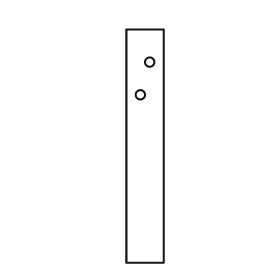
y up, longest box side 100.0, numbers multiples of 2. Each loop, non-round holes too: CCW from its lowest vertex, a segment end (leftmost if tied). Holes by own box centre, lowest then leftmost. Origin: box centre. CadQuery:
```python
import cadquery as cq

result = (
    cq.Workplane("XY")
    .moveTo(-8.0, -50.0)
    .lineTo(8.0, -50.0)
    .lineTo(8.0, 50.0)
    .lineTo(-8.0, 50.0)
    .close()
    .moveTo(-2.0, 22.0)
    .circle(2.0)
    .moveTo(2.0, 36.0)
    .circle(2.0)
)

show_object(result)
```